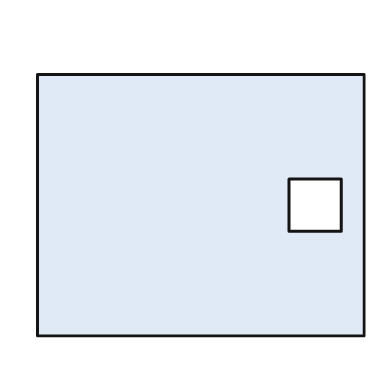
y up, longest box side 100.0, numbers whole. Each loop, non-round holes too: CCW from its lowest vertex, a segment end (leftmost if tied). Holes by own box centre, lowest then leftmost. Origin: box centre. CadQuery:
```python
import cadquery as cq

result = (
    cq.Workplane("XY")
    .moveTo(-50.0, -40.0)
    .lineTo(50.0, -40.0)
    .lineTo(50.0, 40.0)
    .lineTo(-50.0, 40.0)
    .close()
    .moveTo(27.0, -8.0)
    .lineTo(43.0, -8.0)
    .lineTo(43.0, 8.0)
    .lineTo(27.0, 8.0)
    .close()
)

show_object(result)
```